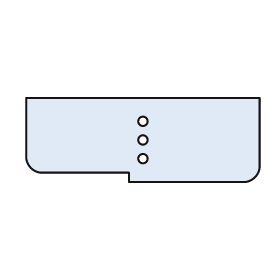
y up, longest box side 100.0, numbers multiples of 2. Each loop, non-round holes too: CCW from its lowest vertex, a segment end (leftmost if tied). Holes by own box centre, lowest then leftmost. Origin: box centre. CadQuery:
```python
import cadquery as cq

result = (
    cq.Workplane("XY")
    .moveTo(-6.0, -18.0)
    .lineTo(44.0, -18.0)
    .threePointArc((48.0, -16.0), (50.0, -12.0))
    .lineTo(50.0, 18.0)
    .lineTo(-50.0, 18.0)
    .lineTo(-50.0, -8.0)
    .threePointArc((-48.0, -12.0), (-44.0, -14.0))
    .lineTo(-6.0, -14.0)
    .close()
    .moveTo(0.0, -8.0)
    .circle(2.0)
    .moveTo(0.0, 0.0)
    .circle(2.0)
    .moveTo(0.0, 8.0)
    .circle(2.0)
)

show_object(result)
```